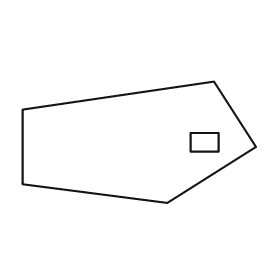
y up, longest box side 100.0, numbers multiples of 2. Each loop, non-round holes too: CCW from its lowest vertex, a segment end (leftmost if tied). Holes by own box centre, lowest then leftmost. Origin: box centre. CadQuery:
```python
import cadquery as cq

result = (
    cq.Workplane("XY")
    .moveTo(12.0, -26.0)
    .lineTo(50.0, -2.0)
    .lineTo(32.0, 26.0)
    .lineTo(-50.0, 14.0)
    .lineTo(-50.0, -18.0)
    .close()
    .moveTo(22.0, -4.0)
    .lineTo(34.0, -4.0)
    .lineTo(34.0, 4.0)
    .lineTo(22.0, 4.0)
    .close()
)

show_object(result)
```